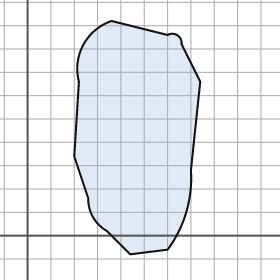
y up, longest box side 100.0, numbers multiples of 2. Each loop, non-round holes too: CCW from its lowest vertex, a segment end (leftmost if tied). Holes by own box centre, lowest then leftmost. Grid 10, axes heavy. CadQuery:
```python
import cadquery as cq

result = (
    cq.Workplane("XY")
    .moveTo(44.0, -8.0)
    .lineTo(60.0, -6.0)
    .threePointArc((68.0, 10.0), (70.0, 28.0))
    .lineTo(74.0, 66.0)
    .lineTo(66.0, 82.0)
    .threePointArc((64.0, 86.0), (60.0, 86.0))
    .lineTo(36.0, 92.0)
    .threePointArc((24.0, 82.0), (22.0, 66.0))
    .lineTo(20.0, 34.0)
    .lineTo(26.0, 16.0)
    .threePointArc((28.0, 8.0), (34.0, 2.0))
    .close()
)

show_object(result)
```